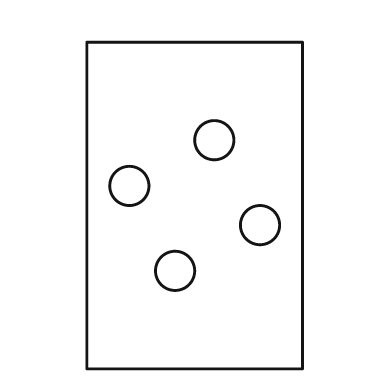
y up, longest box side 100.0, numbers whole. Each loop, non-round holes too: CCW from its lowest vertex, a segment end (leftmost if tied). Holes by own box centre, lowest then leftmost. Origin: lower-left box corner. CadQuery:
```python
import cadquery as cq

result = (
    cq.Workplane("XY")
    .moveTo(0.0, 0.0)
    .lineTo(66.0, 0.0)
    .lineTo(66.0, 100.0)
    .lineTo(0.0, 100.0)
    .close()
    .moveTo(27.0, 30.0)
    .circle(6.0)
    .moveTo(53.0, 44.0)
    .circle(6.0)
    .moveTo(13.0, 56.0)
    .circle(6.0)
    .moveTo(39.0, 70.0)
    .circle(6.0)
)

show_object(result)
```